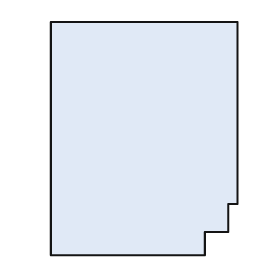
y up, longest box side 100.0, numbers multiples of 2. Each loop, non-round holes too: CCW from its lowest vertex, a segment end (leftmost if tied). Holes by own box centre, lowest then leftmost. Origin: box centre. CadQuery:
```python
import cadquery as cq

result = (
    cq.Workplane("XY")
    .moveTo(-40.0, -50.0)
    .lineTo(26.0, -50.0)
    .lineTo(26.0, -40.0)
    .lineTo(36.0, -40.0)
    .lineTo(36.0, -28.0)
    .lineTo(40.0, -28.0)
    .lineTo(40.0, 50.0)
    .lineTo(-40.0, 50.0)
    .close()
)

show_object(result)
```